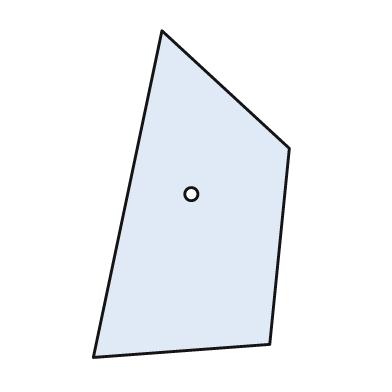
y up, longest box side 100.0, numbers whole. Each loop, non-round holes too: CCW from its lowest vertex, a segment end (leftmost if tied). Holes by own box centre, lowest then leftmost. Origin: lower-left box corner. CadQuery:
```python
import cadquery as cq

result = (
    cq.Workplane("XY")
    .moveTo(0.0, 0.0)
    .lineTo(54.0, 4.0)
    .lineTo(60.0, 64.0)
    .lineTo(21.0, 100.0)
    .close()
    .moveTo(30.0, 50.0)
    .circle(2.0)
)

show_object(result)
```